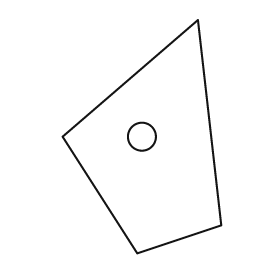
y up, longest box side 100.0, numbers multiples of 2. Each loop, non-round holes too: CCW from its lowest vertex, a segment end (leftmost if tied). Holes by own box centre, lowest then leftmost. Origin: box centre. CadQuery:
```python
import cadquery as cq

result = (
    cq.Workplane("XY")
    .moveTo(-2.0, -50.0)
    .lineTo(34.0, -38.0)
    .lineTo(24.0, 50.0)
    .lineTo(-34.0, 0.0)
    .close()
    .moveTo(0.0, 0.0)
    .circle(6.0)
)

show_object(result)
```